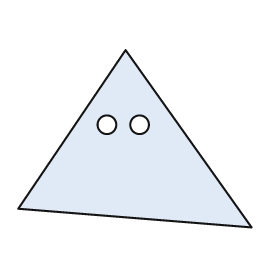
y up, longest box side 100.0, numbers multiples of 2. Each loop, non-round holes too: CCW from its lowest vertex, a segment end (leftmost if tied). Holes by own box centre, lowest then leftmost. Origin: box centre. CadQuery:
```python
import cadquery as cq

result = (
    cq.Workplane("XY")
    .moveTo(50.0, -38.0)
    .lineTo(-4.0, 38.0)
    .lineTo(-50.0, -30.0)
    .close()
    .moveTo(-12.0, 6.0)
    .circle(4.0)
    .moveTo(2.0, 6.0)
    .circle(4.0)
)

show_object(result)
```